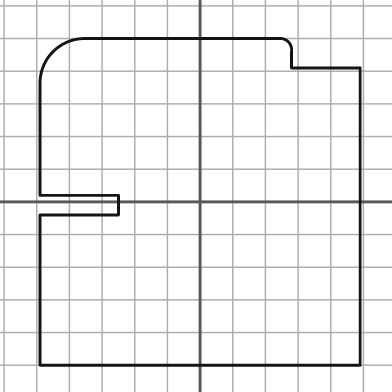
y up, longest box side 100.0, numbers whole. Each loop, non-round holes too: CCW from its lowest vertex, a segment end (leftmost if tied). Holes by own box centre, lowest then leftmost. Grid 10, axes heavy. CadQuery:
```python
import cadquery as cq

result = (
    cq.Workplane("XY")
    .moveTo(-49.0, -50.0)
    .lineTo(49.0, -50.0)
    .lineTo(49.0, 41.0)
    .lineTo(28.0, 41.0)
    .lineTo(28.0, 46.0)
    .threePointArc((27.0, 49.0), (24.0, 50.0))
    .lineTo(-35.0, 50.0)
    .threePointArc((-45.0, 46.0), (-49.0, 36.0))
    .lineTo(-49.0, 2.0)
    .lineTo(-25.0, 2.0)
    .lineTo(-25.0, -4.0)
    .lineTo(-49.0, -4.0)
    .close()
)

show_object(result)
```